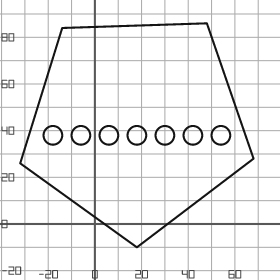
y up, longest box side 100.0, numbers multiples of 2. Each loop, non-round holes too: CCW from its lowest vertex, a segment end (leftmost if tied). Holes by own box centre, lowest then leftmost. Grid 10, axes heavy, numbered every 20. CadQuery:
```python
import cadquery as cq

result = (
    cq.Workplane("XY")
    .moveTo(18.0, -10.0)
    .lineTo(68.0, 28.0)
    .lineTo(48.0, 86.0)
    .lineTo(-14.0, 84.0)
    .lineTo(-32.0, 26.0)
    .close()
    .moveTo(-18.0, 38.0)
    .circle(4.0)
    .moveTo(-6.0, 38.0)
    .circle(4.0)
    .moveTo(6.0, 38.0)
    .circle(4.0)
    .moveTo(18.0, 38.0)
    .circle(4.0)
    .moveTo(30.0, 38.0)
    .circle(4.0)
    .moveTo(42.0, 38.0)
    .circle(4.0)
    .moveTo(54.0, 38.0)
    .circle(4.0)
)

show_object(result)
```